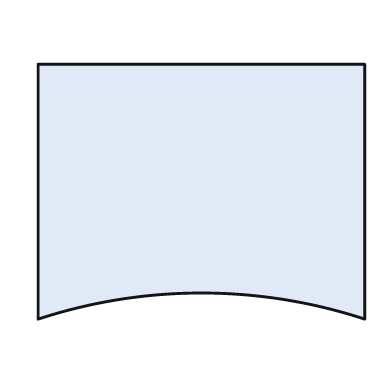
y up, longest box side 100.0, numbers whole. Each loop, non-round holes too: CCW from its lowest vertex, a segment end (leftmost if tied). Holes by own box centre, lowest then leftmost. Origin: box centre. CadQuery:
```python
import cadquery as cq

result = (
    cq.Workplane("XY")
    .moveTo(-50.0, -39.0)
    .threePointArc((0.0, -31.0), (50.0, -39.0))
    .lineTo(50.0, 39.0)
    .lineTo(-50.0, 39.0)
    .close()
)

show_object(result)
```